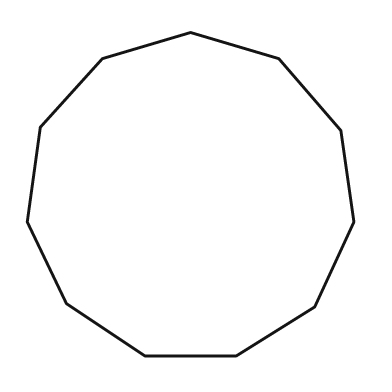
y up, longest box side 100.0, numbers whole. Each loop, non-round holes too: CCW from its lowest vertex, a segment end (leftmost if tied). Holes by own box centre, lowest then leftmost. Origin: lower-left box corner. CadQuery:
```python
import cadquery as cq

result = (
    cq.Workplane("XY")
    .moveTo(36.0, 0.0)
    .lineTo(64.0, 0.0)
    .lineTo(88.0, 15.0)
    .lineTo(100.0, 41.0)
    .lineTo(96.0, 69.0)
    .lineTo(77.0, 91.0)
    .lineTo(50.0, 99.0)
    .lineTo(23.0, 91.0)
    .lineTo(4.0, 70.0)
    .lineTo(0.0, 41.0)
    .lineTo(12.0, 16.0)
    .close()
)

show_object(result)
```